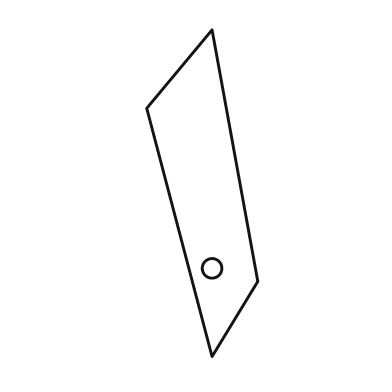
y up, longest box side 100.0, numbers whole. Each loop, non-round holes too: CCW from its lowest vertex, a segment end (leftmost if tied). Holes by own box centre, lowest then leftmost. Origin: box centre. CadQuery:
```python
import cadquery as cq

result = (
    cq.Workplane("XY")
    .moveTo(3.0, -50.0)
    .lineTo(17.0, -27.0)
    .lineTo(3.0, 50.0)
    .lineTo(-17.0, 26.0)
    .close()
    .moveTo(3.0, -23.0)
    .circle(3.0)
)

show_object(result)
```